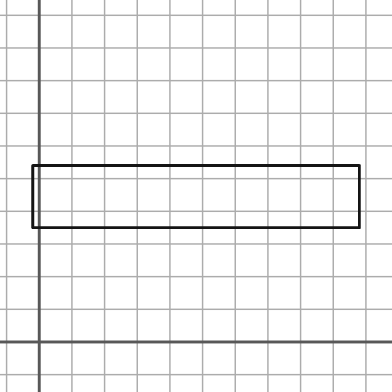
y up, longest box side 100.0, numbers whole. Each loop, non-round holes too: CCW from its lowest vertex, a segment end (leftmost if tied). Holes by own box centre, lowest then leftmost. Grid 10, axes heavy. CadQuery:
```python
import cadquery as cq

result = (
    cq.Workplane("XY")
    .moveTo(-2.0, 35.0)
    .lineTo(98.0, 35.0)
    .lineTo(98.0, 54.0)
    .lineTo(-2.0, 54.0)
    .close()
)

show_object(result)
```